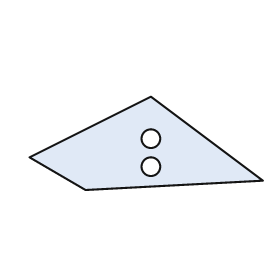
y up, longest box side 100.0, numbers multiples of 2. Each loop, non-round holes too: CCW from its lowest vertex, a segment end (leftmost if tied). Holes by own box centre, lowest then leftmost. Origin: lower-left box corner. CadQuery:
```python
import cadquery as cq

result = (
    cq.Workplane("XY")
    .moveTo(24.0, 0.0)
    .lineTo(100.0, 4.0)
    .lineTo(52.0, 40.0)
    .lineTo(0.0, 14.0)
    .close()
    .moveTo(52.0, 10.0)
    .circle(4.0)
    .moveTo(52.0, 22.0)
    .circle(4.0)
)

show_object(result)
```